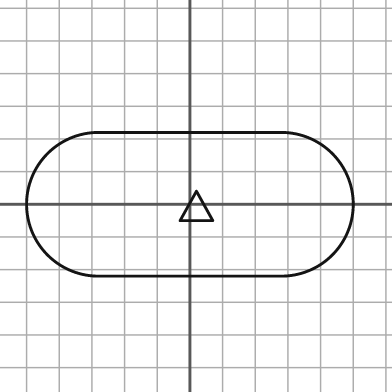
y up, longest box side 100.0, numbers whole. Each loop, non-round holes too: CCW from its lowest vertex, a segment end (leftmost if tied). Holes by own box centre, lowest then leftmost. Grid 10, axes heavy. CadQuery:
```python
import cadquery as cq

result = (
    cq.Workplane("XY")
    .moveTo(-28.0, -22.0)
    .lineTo(28.0, -22.0)
    .threePointArc((50.0, 0.0), (28.0, 22.0))
    .lineTo(-28.0, 22.0)
    .threePointArc((-50.0, 0.0), (-28.0, -22.0))
    .close()
    .moveTo(-3.0, -5.0)
    .lineTo(7.0, -5.0)
    .lineTo(2.0, 4.0)
    .close()
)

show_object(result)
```